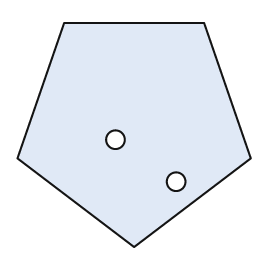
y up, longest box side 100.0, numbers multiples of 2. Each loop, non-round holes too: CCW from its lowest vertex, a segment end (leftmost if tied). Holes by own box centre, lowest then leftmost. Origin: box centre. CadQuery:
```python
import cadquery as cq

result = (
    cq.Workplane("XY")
    .moveTo(0.0, -48.0)
    .lineTo(50.0, -10.0)
    .lineTo(30.0, 48.0)
    .lineTo(-30.0, 48.0)
    .lineTo(-50.0, -10.0)
    .close()
    .moveTo(18.0, -20.0)
    .circle(4.0)
    .moveTo(-8.0, -2.0)
    .circle(4.0)
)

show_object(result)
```